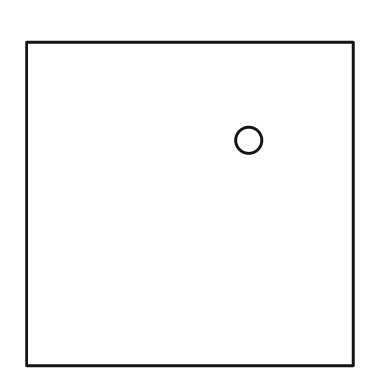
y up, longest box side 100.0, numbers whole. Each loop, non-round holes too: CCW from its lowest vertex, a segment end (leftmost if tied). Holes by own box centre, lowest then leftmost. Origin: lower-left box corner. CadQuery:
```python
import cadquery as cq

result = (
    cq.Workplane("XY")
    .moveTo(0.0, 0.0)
    .lineTo(100.0, 0.0)
    .lineTo(100.0, 99.0)
    .lineTo(0.0, 99.0)
    .close()
    .moveTo(68.0, 69.0)
    .circle(4.0)
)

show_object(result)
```